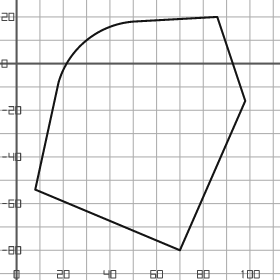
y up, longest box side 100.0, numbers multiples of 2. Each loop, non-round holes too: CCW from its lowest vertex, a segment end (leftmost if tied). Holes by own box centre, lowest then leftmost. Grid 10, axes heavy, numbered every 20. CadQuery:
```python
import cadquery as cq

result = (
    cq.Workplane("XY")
    .moveTo(70.0, -80.0)
    .lineTo(98.0, -16.0)
    .lineTo(86.0, 20.0)
    .lineTo(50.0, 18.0)
    .threePointArc((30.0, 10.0), (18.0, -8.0))
    .lineTo(8.0, -54.0)
    .close()
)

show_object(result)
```